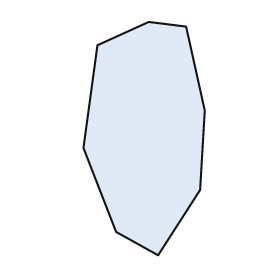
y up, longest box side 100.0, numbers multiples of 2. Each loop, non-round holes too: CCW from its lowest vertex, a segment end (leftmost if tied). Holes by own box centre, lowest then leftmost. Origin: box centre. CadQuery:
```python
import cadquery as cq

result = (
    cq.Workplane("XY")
    .moveTo(6.0, -50.0)
    .lineTo(24.0, -22.0)
    .lineTo(26.0, 12.0)
    .lineTo(18.0, 48.0)
    .lineTo(2.0, 50.0)
    .lineTo(-20.0, 40.0)
    .lineTo(-26.0, -4.0)
    .lineTo(-12.0, -40.0)
    .close()
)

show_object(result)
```